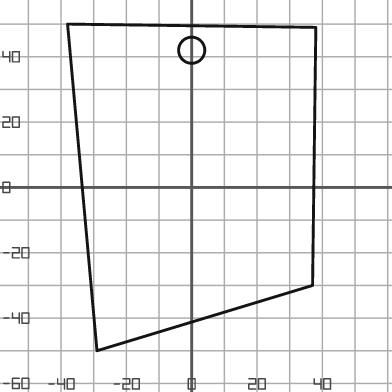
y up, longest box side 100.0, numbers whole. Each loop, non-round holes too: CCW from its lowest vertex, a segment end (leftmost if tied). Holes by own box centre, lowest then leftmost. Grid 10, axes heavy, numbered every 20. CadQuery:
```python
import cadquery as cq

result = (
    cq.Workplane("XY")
    .moveTo(-29.0, -50.0)
    .lineTo(37.0, -30.0)
    .lineTo(38.0, 49.0)
    .lineTo(-38.0, 50.0)
    .close()
    .moveTo(0.0, 42.0)
    .circle(4.0)
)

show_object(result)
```